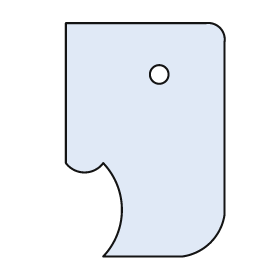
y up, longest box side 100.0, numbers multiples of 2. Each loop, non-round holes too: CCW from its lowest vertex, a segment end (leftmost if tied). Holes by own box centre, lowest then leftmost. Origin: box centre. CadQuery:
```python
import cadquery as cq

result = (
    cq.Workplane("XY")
    .moveTo(-18.0, -50.0)
    .lineTo(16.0, -50.0)
    .threePointArc((28.0, -44.0), (34.0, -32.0))
    .lineTo(34.0, 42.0)
    .threePointArc((32.0, 48.0), (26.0, 50.0))
    .lineTo(-34.0, 50.0)
    .lineTo(-34.0, -10.0)
    .threePointArc((-26.0, -14.0), (-18.0, -10.0))
    .threePointArc((-10.0, -30.0), (-18.0, -50.0))
    .close()
    .moveTo(6.0, 28.0)
    .circle(4.0)
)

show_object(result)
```